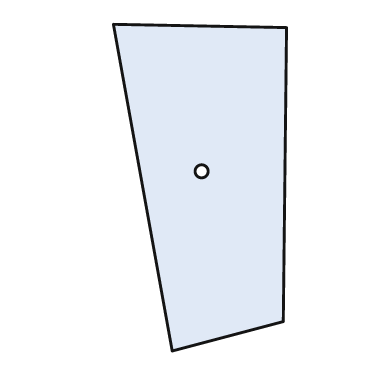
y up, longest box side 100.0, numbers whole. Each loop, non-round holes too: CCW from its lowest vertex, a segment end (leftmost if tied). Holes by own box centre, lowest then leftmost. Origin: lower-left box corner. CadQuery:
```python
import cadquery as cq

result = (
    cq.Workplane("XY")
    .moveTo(18.0, 0.0)
    .lineTo(52.0, 9.0)
    .lineTo(53.0, 99.0)
    .lineTo(0.0, 100.0)
    .close()
    .moveTo(27.0, 55.0)
    .circle(2.0)
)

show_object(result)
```